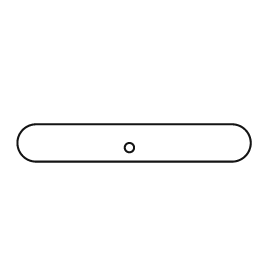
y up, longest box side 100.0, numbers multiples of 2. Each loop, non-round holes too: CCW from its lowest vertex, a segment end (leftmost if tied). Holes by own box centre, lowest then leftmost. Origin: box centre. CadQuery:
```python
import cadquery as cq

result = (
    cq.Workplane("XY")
    .moveTo(-42.0, -8.0)
    .lineTo(42.0, -8.0)
    .threePointArc((50.0, 0.0), (42.0, 8.0))
    .lineTo(-42.0, 8.0)
    .threePointArc((-50.0, 0.0), (-42.0, -8.0))
    .close()
    .moveTo(-2.0, -2.0)
    .circle(2.0)
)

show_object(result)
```